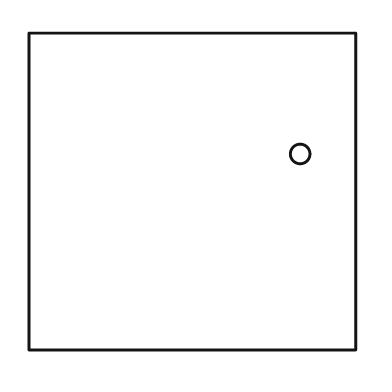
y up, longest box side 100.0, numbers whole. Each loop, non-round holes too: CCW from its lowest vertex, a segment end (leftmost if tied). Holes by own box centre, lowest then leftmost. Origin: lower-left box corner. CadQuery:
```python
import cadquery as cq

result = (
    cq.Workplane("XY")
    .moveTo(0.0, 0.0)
    .lineTo(100.0, 0.0)
    .lineTo(100.0, 97.0)
    .lineTo(0.0, 97.0)
    .close()
    .moveTo(83.0, 60.0)
    .circle(3.0)
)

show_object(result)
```